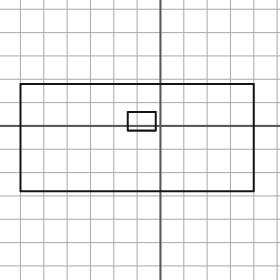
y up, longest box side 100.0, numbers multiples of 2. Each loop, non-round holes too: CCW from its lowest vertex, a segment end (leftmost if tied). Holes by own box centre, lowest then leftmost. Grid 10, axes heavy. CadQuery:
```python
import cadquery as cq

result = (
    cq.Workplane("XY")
    .moveTo(-60.0, -28.0)
    .lineTo(40.0, -28.0)
    .lineTo(40.0, 18.0)
    .lineTo(-60.0, 18.0)
    .close()
    .moveTo(-14.0, -2.0)
    .lineTo(-2.0, -2.0)
    .lineTo(-2.0, 6.0)
    .lineTo(-14.0, 6.0)
    .close()
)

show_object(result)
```